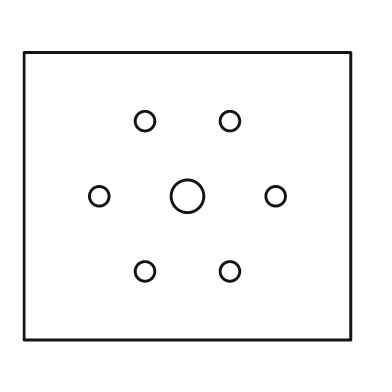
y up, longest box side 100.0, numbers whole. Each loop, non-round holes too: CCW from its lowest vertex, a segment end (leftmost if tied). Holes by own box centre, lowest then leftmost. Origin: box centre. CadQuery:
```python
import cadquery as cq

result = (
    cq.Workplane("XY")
    .moveTo(-50.0, -44.0)
    .lineTo(50.0, -44.0)
    .lineTo(50.0, 44.0)
    .lineTo(-50.0, 44.0)
    .close()
    .moveTo(-13.0, -23.0)
    .circle(3.0)
    .moveTo(13.0, -23.0)
    .circle(3.0)
    .moveTo(-27.0, 0.0)
    .circle(3.0)
    .moveTo(0.0, 0.0)
    .circle(5.0)
    .moveTo(27.0, 0.0)
    .circle(3.0)
    .moveTo(-13.0, 23.0)
    .circle(3.0)
    .moveTo(13.0, 23.0)
    .circle(3.0)
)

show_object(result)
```